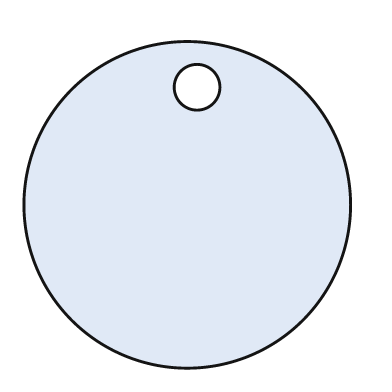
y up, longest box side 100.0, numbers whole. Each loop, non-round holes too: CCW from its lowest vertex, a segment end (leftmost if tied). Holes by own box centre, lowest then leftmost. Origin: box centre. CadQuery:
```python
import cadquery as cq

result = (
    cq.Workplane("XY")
    .moveTo(0.0, 0.0)
    .circle(50.0)
    .moveTo(3.0, 36.0)
    .circle(7.0)
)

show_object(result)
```